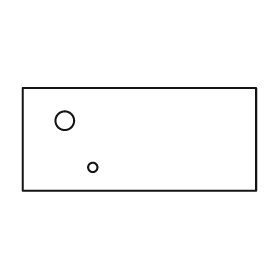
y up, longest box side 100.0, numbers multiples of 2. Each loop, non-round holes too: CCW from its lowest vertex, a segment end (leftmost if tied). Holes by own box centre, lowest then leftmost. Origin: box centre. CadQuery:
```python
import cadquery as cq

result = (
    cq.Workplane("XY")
    .moveTo(-50.0, -22.0)
    .lineTo(50.0, -22.0)
    .lineTo(50.0, 22.0)
    .lineTo(-50.0, 22.0)
    .close()
    .moveTo(-20.0, -12.0)
    .circle(2.0)
    .moveTo(-32.0, 8.0)
    .circle(4.0)
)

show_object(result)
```